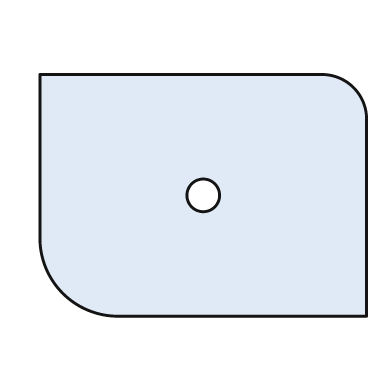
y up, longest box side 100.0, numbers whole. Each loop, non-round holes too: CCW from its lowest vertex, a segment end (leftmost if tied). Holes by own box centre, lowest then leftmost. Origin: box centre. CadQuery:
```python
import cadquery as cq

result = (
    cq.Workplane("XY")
    .moveTo(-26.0, -37.0)
    .lineTo(50.0, -37.0)
    .lineTo(50.0, 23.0)
    .threePointArc((46.0, 33.0), (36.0, 37.0))
    .lineTo(-50.0, 37.0)
    .lineTo(-50.0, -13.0)
    .threePointArc((-43.0, -30.0), (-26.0, -37.0))
    .close()
    .moveTo(0.0, 0.0)
    .circle(5.0)
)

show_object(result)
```